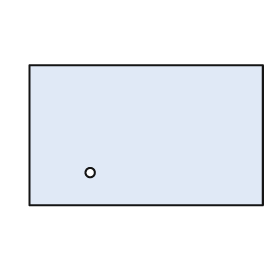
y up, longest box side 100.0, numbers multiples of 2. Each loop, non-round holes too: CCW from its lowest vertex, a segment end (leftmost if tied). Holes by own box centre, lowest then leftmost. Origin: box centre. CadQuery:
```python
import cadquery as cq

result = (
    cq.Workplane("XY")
    .moveTo(-50.0, -30.0)
    .lineTo(50.0, -30.0)
    .lineTo(50.0, 30.0)
    .lineTo(-50.0, 30.0)
    .close()
    .moveTo(-24.0, -16.0)
    .circle(2.0)
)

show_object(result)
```